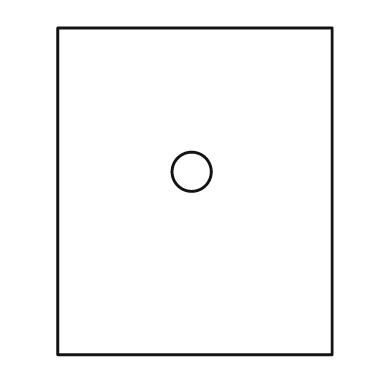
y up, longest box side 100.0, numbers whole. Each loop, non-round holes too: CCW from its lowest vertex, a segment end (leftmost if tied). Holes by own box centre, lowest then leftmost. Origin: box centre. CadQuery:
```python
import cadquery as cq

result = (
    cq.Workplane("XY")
    .moveTo(-42.0, -50.0)
    .lineTo(42.0, -50.0)
    .lineTo(42.0, 50.0)
    .lineTo(-42.0, 50.0)
    .close()
    .moveTo(-1.0, 6.0)
    .circle(6.0)
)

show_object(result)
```